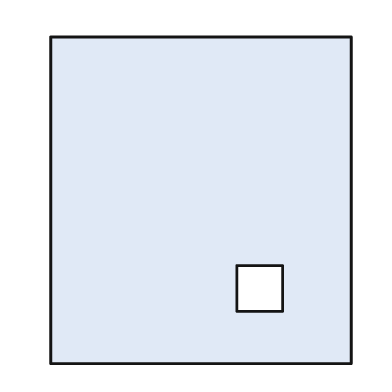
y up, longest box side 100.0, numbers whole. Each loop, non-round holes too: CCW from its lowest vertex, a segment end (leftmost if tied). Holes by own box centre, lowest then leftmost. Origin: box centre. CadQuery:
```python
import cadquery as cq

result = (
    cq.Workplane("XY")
    .moveTo(-46.0, -50.0)
    .lineTo(46.0, -50.0)
    .lineTo(46.0, 50.0)
    .lineTo(-46.0, 50.0)
    .close()
    .moveTo(11.0, -34.0)
    .lineTo(25.0, -34.0)
    .lineTo(25.0, -20.0)
    .lineTo(11.0, -20.0)
    .close()
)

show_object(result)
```